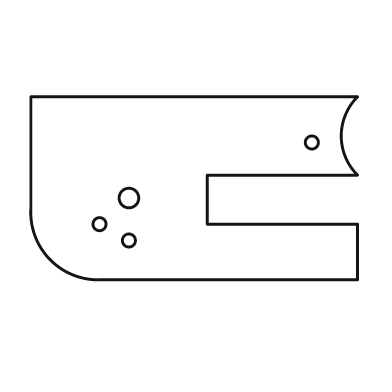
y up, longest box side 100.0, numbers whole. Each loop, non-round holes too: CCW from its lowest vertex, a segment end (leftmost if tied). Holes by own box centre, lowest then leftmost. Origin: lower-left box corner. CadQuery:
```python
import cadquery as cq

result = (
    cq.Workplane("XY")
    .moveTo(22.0, 0.0)
    .lineTo(100.0, 0.0)
    .lineTo(100.0, 17.0)
    .lineTo(54.0, 17.0)
    .lineTo(54.0, 32.0)
    .lineTo(100.0, 32.0)
    .threePointArc((95.0, 44.0), (100.0, 56.0))
    .lineTo(0.0, 56.0)
    .lineTo(0.0, 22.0)
    .threePointArc((6.0, 6.0), (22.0, 0.0))
    .close()
    .moveTo(30.0, 12.0)
    .circle(2.0)
    .moveTo(21.0, 17.0)
    .circle(2.0)
    .moveTo(30.0, 25.0)
    .circle(3.0)
    .moveTo(86.0, 42.0)
    .circle(2.0)
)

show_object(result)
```